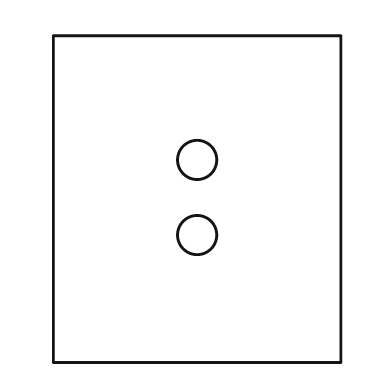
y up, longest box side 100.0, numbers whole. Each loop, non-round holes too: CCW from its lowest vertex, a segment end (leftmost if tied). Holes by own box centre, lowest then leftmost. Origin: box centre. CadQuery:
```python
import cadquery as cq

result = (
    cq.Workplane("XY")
    .moveTo(-44.0, -50.0)
    .lineTo(44.0, -50.0)
    .lineTo(44.0, 50.0)
    .lineTo(-44.0, 50.0)
    .close()
    .moveTo(0.0, -11.0)
    .circle(6.0)
    .moveTo(0.0, 12.0)
    .circle(6.0)
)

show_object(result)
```